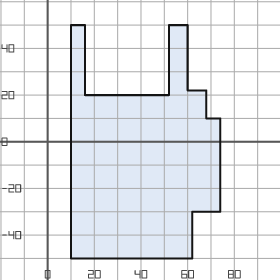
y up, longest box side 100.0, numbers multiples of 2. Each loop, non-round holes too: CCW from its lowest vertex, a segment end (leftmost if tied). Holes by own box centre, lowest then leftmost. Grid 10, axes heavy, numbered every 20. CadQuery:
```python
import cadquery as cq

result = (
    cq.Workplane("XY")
    .moveTo(10.0, -50.0)
    .lineTo(62.0, -50.0)
    .lineTo(62.0, -30.0)
    .lineTo(74.0, -30.0)
    .lineTo(74.0, 10.0)
    .lineTo(68.0, 10.0)
    .lineTo(68.0, 22.0)
    .lineTo(60.0, 22.0)
    .lineTo(60.0, 50.0)
    .lineTo(52.0, 50.0)
    .lineTo(52.0, 20.0)
    .lineTo(16.0, 20.0)
    .lineTo(16.0, 50.0)
    .lineTo(10.0, 50.0)
    .close()
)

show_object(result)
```